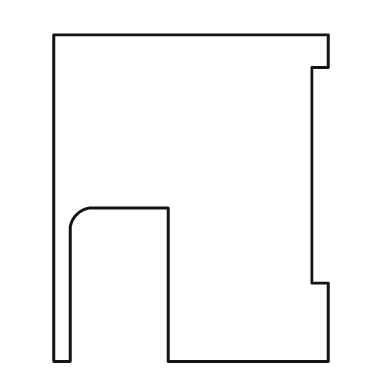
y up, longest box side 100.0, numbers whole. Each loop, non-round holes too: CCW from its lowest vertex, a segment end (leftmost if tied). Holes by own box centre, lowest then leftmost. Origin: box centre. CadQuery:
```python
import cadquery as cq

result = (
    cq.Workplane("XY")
    .moveTo(-42.0, -50.0)
    .lineTo(-37.0, -50.0)
    .lineTo(-37.0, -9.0)
    .threePointArc((-35.0, -5.0), (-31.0, -3.0))
    .lineTo(-7.0, -3.0)
    .lineTo(-7.0, -50.0)
    .lineTo(42.0, -50.0)
    .lineTo(42.0, -26.0)
    .lineTo(37.0, -26.0)
    .lineTo(37.0, 40.0)
    .lineTo(42.0, 40.0)
    .lineTo(42.0, 50.0)
    .lineTo(-42.0, 50.0)
    .close()
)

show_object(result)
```